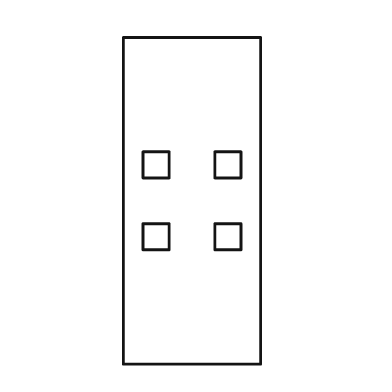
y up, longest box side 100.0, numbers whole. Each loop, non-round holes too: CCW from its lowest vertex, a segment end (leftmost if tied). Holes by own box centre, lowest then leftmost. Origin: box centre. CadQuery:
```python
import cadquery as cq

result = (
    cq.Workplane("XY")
    .moveTo(-21.0, -50.0)
    .lineTo(21.0, -50.0)
    .lineTo(21.0, 50.0)
    .lineTo(-21.0, 50.0)
    .close()
    .moveTo(-15.0, -15.0)
    .lineTo(-7.0, -15.0)
    .lineTo(-7.0, -7.0)
    .lineTo(-15.0, -7.0)
    .close()
    .moveTo(7.0, -15.0)
    .lineTo(15.0, -15.0)
    .lineTo(15.0, -7.0)
    .lineTo(7.0, -7.0)
    .close()
    .moveTo(-15.0, 7.0)
    .lineTo(-7.0, 7.0)
    .lineTo(-7.0, 15.0)
    .lineTo(-15.0, 15.0)
    .close()
    .moveTo(7.0, 7.0)
    .lineTo(15.0, 7.0)
    .lineTo(15.0, 15.0)
    .lineTo(7.0, 15.0)
    .close()
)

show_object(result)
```